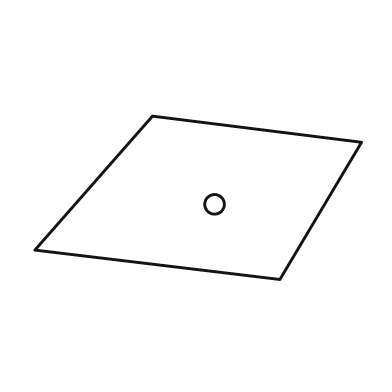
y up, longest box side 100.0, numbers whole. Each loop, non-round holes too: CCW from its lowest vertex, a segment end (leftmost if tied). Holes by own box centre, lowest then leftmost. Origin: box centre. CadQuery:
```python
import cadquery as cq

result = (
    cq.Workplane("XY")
    .moveTo(25.0, -25.0)
    .lineTo(50.0, 17.0)
    .lineTo(-14.0, 25.0)
    .lineTo(-50.0, -16.0)
    .close()
    .moveTo(5.0, -2.0)
    .circle(3.0)
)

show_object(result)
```